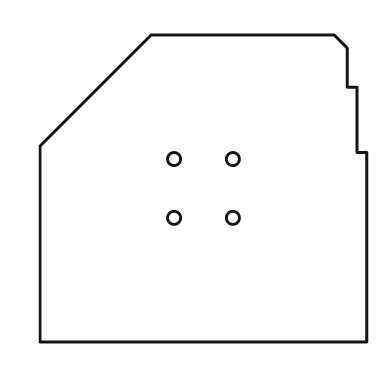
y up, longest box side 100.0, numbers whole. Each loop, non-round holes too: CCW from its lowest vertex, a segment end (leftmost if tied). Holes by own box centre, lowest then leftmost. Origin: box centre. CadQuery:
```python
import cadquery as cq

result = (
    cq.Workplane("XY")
    .moveTo(-50.0, -47.0)
    .lineTo(50.0, -47.0)
    .lineTo(50.0, 11.0)
    .lineTo(47.0, 11.0)
    .lineTo(47.0, 31.0)
    .lineTo(44.0, 31.0)
    .lineTo(44.0, 43.0)
    .lineTo(40.0, 47.0)
    .lineTo(-16.0, 47.0)
    .lineTo(-50.0, 13.0)
    .close()
    .moveTo(-9.0, -9.0)
    .circle(2.0)
    .moveTo(9.0, -9.0)
    .circle(2.0)
    .moveTo(-9.0, 9.0)
    .circle(2.0)
    .moveTo(9.0, 9.0)
    .circle(2.0)
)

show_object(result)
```